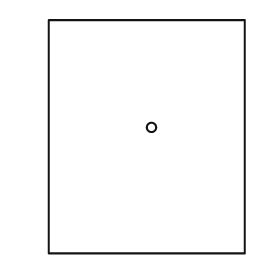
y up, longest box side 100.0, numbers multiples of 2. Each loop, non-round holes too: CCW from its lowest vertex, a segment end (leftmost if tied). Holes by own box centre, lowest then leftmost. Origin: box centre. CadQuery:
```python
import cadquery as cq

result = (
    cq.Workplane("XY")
    .moveTo(-42.0, -50.0)
    .lineTo(42.0, -50.0)
    .lineTo(42.0, 50.0)
    .lineTo(-42.0, 50.0)
    .close()
    .moveTo(2.0, 4.0)
    .circle(2.0)
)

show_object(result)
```